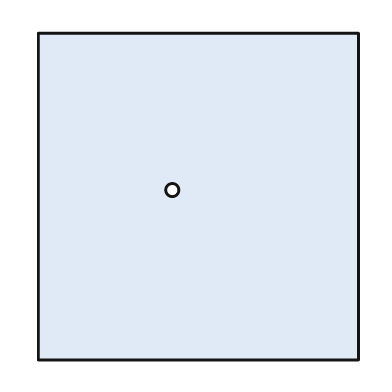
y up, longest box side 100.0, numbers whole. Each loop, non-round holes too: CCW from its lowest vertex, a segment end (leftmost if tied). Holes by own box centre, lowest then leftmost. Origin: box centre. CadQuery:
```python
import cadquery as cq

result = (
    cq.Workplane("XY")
    .moveTo(-49.0, -50.0)
    .lineTo(49.0, -50.0)
    .lineTo(49.0, 50.0)
    .lineTo(-49.0, 50.0)
    .close()
    .moveTo(-8.0, 2.0)
    .circle(2.0)
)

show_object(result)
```